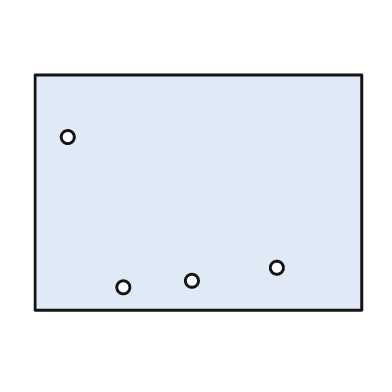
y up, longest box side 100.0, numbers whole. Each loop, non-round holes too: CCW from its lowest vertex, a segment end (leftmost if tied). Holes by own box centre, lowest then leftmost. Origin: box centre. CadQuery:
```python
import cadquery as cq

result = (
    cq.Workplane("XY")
    .moveTo(-50.0, -36.0)
    .lineTo(50.0, -36.0)
    .lineTo(50.0, 36.0)
    .lineTo(-50.0, 36.0)
    .close()
    .moveTo(-23.0, -29.0)
    .circle(2.0)
    .moveTo(-2.0, -27.0)
    .circle(2.0)
    .moveTo(24.0, -23.0)
    .circle(2.0)
    .moveTo(-40.0, 17.0)
    .circle(2.0)
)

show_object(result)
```